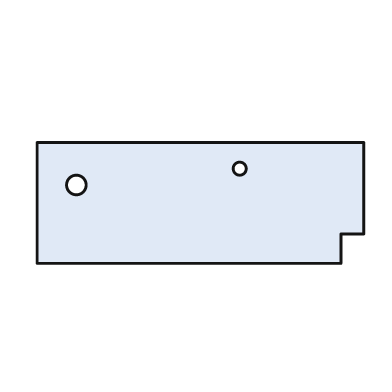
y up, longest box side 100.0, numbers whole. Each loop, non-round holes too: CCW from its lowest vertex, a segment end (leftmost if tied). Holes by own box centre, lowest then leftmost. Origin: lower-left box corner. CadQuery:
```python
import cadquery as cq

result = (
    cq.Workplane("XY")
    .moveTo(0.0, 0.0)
    .lineTo(93.0, 0.0)
    .lineTo(93.0, 9.0)
    .lineTo(100.0, 9.0)
    .lineTo(100.0, 37.0)
    .lineTo(0.0, 37.0)
    .close()
    .moveTo(12.0, 24.0)
    .circle(3.0)
    .moveTo(62.0, 29.0)
    .circle(2.0)
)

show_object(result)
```